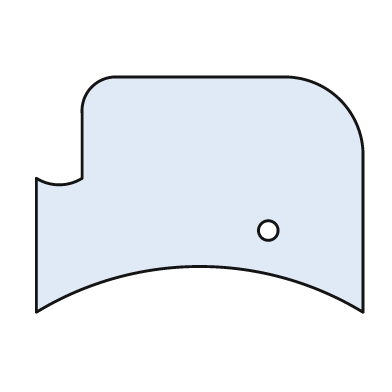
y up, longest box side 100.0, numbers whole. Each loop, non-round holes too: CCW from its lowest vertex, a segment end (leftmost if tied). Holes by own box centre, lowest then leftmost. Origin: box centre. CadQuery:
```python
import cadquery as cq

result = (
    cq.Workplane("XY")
    .moveTo(-50.0, -36.0)
    .threePointArc((0.0, -22.0), (50.0, -36.0))
    .lineTo(50.0, 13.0)
    .threePointArc((43.0, 29.0), (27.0, 36.0))
    .lineTo(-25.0, 36.0)
    .threePointArc((-33.0, 33.0), (-36.0, 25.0))
    .lineTo(-36.0, 5.0)
    .threePointArc((-43.0, 3.0), (-50.0, 5.0))
    .close()
    .moveTo(21.0, -11.0)
    .circle(3.0)
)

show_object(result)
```